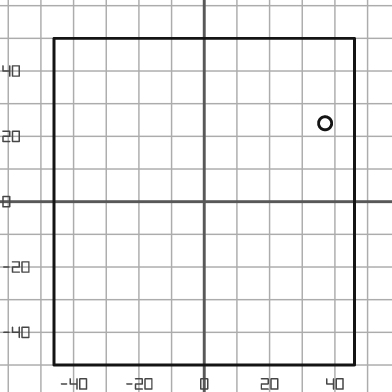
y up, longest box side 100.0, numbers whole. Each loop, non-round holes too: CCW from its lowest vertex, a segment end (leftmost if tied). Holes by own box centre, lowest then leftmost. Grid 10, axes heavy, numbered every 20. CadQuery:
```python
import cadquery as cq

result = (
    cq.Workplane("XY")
    .moveTo(-46.0, -50.0)
    .lineTo(46.0, -50.0)
    .lineTo(46.0, 50.0)
    .lineTo(-46.0, 50.0)
    .close()
    .moveTo(37.0, 24.0)
    .circle(2.0)
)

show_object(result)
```